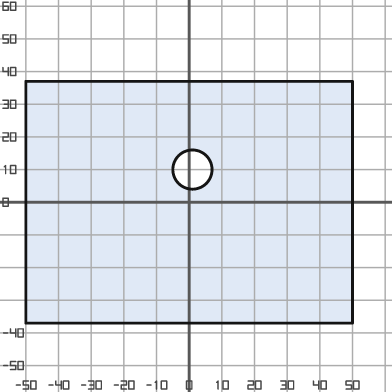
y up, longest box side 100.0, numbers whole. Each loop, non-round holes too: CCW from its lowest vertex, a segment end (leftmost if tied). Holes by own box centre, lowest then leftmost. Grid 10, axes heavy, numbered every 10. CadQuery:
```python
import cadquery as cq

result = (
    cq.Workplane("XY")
    .moveTo(-50.0, -37.0)
    .lineTo(50.0, -37.0)
    .lineTo(50.0, 37.0)
    .lineTo(-50.0, 37.0)
    .close()
    .moveTo(1.0, 10.0)
    .circle(6.0)
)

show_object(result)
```